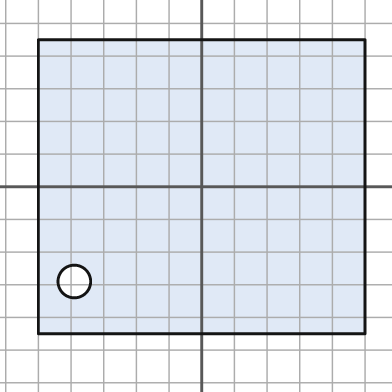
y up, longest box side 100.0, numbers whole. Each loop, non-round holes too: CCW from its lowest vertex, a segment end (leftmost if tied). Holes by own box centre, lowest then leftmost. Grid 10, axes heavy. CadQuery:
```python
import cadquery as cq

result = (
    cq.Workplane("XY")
    .moveTo(-50.0, -45.0)
    .lineTo(50.0, -45.0)
    .lineTo(50.0, 45.0)
    .lineTo(-50.0, 45.0)
    .close()
    .moveTo(-39.0, -29.0)
    .circle(5.0)
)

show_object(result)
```